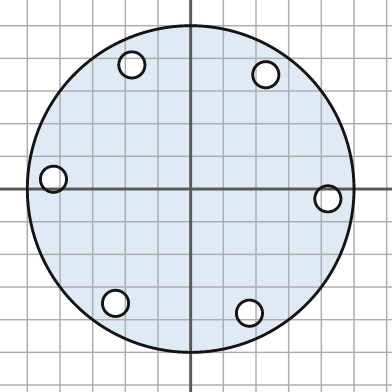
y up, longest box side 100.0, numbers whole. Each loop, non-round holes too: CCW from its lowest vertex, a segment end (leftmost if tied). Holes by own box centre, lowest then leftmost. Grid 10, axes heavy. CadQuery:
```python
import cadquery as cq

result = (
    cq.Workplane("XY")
    .moveTo(0.0, 0.0)
    .circle(50.0)
    .moveTo(18.0, -38.0)
    .circle(4.0)
    .moveTo(-23.0, -35.0)
    .circle(4.0)
    .moveTo(42.0, -3.0)
    .circle(4.0)
    .moveTo(-42.0, 3.0)
    .circle(4.0)
    .moveTo(23.0, 35.0)
    .circle(4.0)
    .moveTo(-18.0, 38.0)
    .circle(4.0)
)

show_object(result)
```